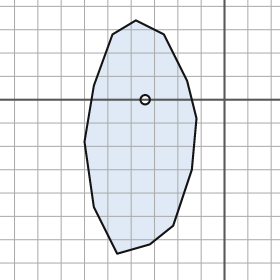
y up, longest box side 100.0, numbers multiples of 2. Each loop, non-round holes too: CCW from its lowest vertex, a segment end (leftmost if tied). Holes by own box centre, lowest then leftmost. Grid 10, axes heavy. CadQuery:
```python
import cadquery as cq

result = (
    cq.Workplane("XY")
    .moveTo(-46.0, -66.0)
    .lineTo(-32.0, -62.0)
    .lineTo(-22.0, -54.0)
    .lineTo(-14.0, -30.0)
    .lineTo(-12.0, -8.0)
    .lineTo(-16.0, 8.0)
    .lineTo(-26.0, 28.0)
    .lineTo(-38.0, 34.0)
    .lineTo(-48.0, 28.0)
    .lineTo(-56.0, 6.0)
    .lineTo(-60.0, -18.0)
    .lineTo(-56.0, -46.0)
    .close()
    .moveTo(-34.0, 0.0)
    .circle(2.0)
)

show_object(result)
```